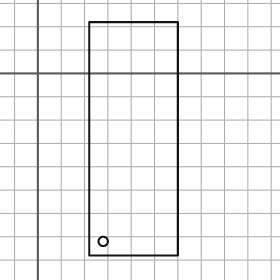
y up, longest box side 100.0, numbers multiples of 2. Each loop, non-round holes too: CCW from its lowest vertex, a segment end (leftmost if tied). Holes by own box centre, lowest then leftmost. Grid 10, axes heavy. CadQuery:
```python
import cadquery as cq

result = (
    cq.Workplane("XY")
    .moveTo(22.0, -78.0)
    .lineTo(60.0, -78.0)
    .lineTo(60.0, 22.0)
    .lineTo(22.0, 22.0)
    .close()
    .moveTo(28.0, -72.0)
    .circle(2.0)
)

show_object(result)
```